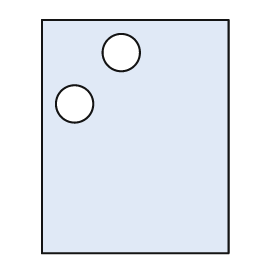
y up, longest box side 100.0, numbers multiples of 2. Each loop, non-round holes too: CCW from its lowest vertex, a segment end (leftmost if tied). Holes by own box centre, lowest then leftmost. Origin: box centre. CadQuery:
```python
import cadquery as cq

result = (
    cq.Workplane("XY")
    .moveTo(-40.0, -50.0)
    .lineTo(40.0, -50.0)
    .lineTo(40.0, 50.0)
    .lineTo(-40.0, 50.0)
    .close()
    .moveTo(-26.0, 14.0)
    .circle(8.0)
    .moveTo(-6.0, 36.0)
    .circle(8.0)
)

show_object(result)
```